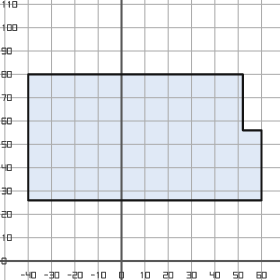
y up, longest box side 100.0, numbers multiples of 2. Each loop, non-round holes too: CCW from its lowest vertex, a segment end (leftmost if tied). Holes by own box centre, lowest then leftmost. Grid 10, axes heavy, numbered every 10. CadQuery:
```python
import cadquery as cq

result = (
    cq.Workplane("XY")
    .moveTo(-40.0, 26.0)
    .lineTo(60.0, 26.0)
    .lineTo(60.0, 56.0)
    .lineTo(52.0, 56.0)
    .lineTo(52.0, 80.0)
    .lineTo(-40.0, 80.0)
    .close()
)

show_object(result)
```